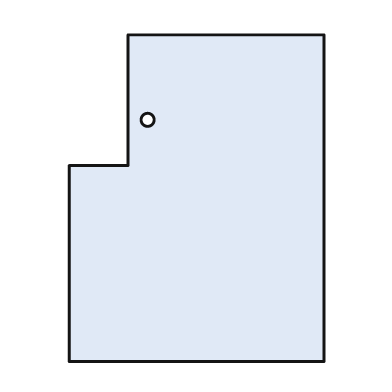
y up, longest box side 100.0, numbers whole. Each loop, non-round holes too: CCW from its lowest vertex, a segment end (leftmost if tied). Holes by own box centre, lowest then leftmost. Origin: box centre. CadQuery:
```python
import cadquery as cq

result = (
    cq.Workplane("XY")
    .moveTo(-39.0, -50.0)
    .lineTo(39.0, -50.0)
    .lineTo(39.0, 50.0)
    .lineTo(-21.0, 50.0)
    .lineTo(-21.0, 10.0)
    .lineTo(-39.0, 10.0)
    .close()
    .moveTo(-15.0, 24.0)
    .circle(2.0)
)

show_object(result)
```